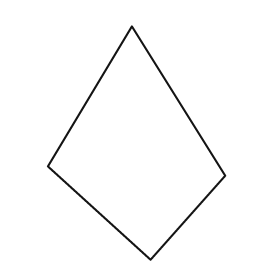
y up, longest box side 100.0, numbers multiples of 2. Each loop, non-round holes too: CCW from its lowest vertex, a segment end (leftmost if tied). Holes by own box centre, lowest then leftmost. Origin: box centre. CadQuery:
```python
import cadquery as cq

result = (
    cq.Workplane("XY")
    .moveTo(6.0, -50.0)
    .lineTo(38.0, -14.0)
    .lineTo(-2.0, 50.0)
    .lineTo(-38.0, -10.0)
    .close()
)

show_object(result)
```